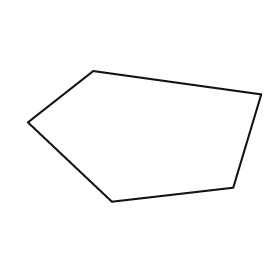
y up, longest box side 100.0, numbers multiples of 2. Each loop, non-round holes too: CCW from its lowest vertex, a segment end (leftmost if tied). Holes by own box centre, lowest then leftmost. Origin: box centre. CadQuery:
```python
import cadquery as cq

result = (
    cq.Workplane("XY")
    .moveTo(-14.0, -28.0)
    .lineTo(38.0, -22.0)
    .lineTo(50.0, 18.0)
    .lineTo(-22.0, 28.0)
    .lineTo(-50.0, 6.0)
    .close()
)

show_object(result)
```